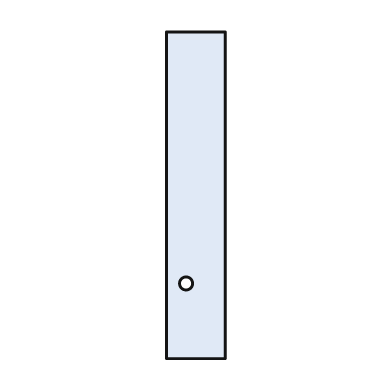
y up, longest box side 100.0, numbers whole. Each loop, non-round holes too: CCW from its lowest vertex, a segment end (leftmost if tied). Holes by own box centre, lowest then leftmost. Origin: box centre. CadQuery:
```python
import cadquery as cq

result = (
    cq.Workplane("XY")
    .moveTo(-9.0, -50.0)
    .lineTo(9.0, -50.0)
    .lineTo(9.0, 50.0)
    .lineTo(-9.0, 50.0)
    .close()
    .moveTo(-3.0, -27.0)
    .circle(2.0)
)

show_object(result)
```